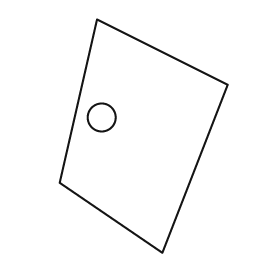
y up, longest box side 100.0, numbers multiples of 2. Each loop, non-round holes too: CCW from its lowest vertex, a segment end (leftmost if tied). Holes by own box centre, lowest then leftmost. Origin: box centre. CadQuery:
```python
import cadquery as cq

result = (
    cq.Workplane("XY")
    .moveTo(8.0, -50.0)
    .lineTo(36.0, 22.0)
    .lineTo(-20.0, 50.0)
    .lineTo(-36.0, -20.0)
    .close()
    .moveTo(-18.0, 8.0)
    .circle(6.0)
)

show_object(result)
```